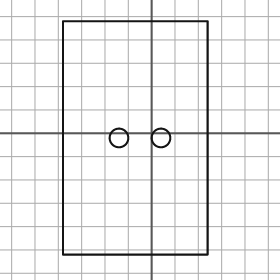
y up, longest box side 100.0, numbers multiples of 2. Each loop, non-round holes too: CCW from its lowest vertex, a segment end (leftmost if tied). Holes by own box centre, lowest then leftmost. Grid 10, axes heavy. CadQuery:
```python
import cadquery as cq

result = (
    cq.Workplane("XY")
    .moveTo(-38.0, -52.0)
    .lineTo(24.0, -52.0)
    .lineTo(24.0, 48.0)
    .lineTo(-38.0, 48.0)
    .close()
    .moveTo(-14.0, -2.0)
    .circle(4.0)
    .moveTo(4.0, -2.0)
    .circle(4.0)
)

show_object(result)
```